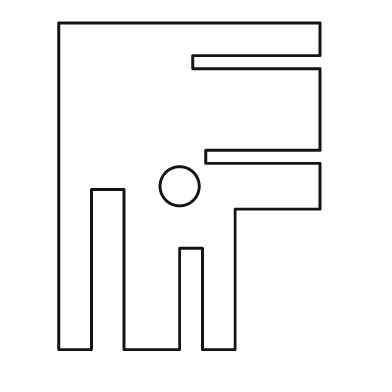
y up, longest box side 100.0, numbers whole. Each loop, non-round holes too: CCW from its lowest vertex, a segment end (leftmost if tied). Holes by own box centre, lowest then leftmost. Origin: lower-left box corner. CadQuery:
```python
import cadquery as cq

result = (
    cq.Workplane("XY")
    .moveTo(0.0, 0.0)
    .lineTo(10.0, 0.0)
    .lineTo(10.0, 49.0)
    .lineTo(20.0, 49.0)
    .lineTo(20.0, 0.0)
    .lineTo(37.0, 0.0)
    .lineTo(37.0, 31.0)
    .lineTo(44.0, 31.0)
    .lineTo(44.0, 0.0)
    .lineTo(54.0, 0.0)
    .lineTo(54.0, 43.0)
    .lineTo(80.0, 43.0)
    .lineTo(80.0, 57.0)
    .lineTo(45.0, 57.0)
    .lineTo(45.0, 61.0)
    .lineTo(80.0, 61.0)
    .lineTo(80.0, 86.0)
    .lineTo(41.0, 86.0)
    .lineTo(41.0, 90.0)
    .lineTo(80.0, 90.0)
    .lineTo(80.0, 100.0)
    .lineTo(0.0, 100.0)
    .close()
    .moveTo(37.0, 50.0)
    .circle(6.0)
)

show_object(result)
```